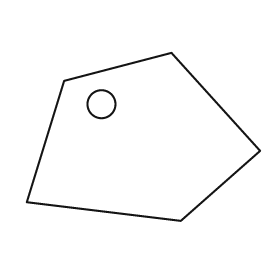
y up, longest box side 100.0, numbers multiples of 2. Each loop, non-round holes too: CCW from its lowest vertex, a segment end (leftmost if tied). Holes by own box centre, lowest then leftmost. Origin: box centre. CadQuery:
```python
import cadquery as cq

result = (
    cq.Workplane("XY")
    .moveTo(16.0, -36.0)
    .lineTo(50.0, -6.0)
    .lineTo(12.0, 36.0)
    .lineTo(-34.0, 24.0)
    .lineTo(-50.0, -28.0)
    .close()
    .moveTo(-18.0, 14.0)
    .circle(6.0)
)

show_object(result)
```